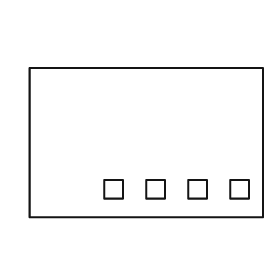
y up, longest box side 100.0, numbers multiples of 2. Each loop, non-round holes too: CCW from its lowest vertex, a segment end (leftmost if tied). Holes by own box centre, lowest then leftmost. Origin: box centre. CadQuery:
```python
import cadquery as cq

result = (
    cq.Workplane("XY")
    .moveTo(-50.0, -32.0)
    .lineTo(50.0, -32.0)
    .lineTo(50.0, 32.0)
    .lineTo(-50.0, 32.0)
    .close()
    .moveTo(-18.0, -24.0)
    .lineTo(-10.0, -24.0)
    .lineTo(-10.0, -16.0)
    .lineTo(-18.0, -16.0)
    .close()
    .moveTo(0.0, -24.0)
    .lineTo(8.0, -24.0)
    .lineTo(8.0, -16.0)
    .lineTo(0.0, -16.0)
    .close()
    .moveTo(18.0, -24.0)
    .lineTo(26.0, -24.0)
    .lineTo(26.0, -16.0)
    .lineTo(18.0, -16.0)
    .close()
    .moveTo(36.0, -24.0)
    .lineTo(44.0, -24.0)
    .lineTo(44.0, -16.0)
    .lineTo(36.0, -16.0)
    .close()
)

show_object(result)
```